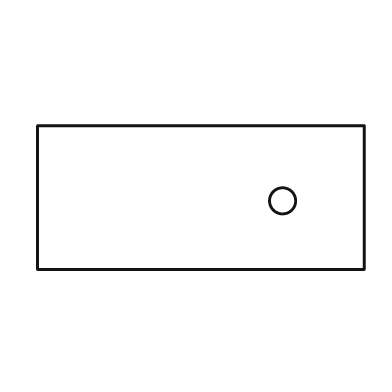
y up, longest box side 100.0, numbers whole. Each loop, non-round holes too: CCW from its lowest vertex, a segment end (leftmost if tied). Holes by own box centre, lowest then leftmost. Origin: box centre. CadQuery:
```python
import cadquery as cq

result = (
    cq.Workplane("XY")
    .moveTo(-50.0, -22.0)
    .lineTo(50.0, -22.0)
    .lineTo(50.0, 22.0)
    .lineTo(-50.0, 22.0)
    .close()
    .moveTo(25.0, -1.0)
    .circle(4.0)
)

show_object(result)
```